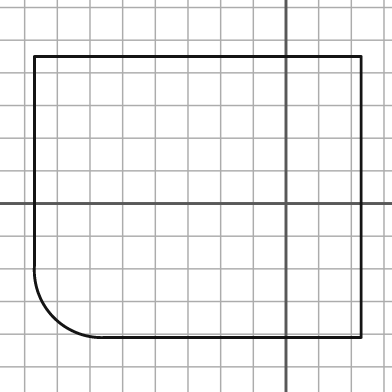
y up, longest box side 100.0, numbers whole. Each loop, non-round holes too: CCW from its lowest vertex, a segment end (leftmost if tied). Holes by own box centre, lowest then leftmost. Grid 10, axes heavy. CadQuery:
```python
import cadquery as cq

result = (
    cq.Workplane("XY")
    .moveTo(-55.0, -41.0)
    .lineTo(23.0, -41.0)
    .lineTo(23.0, 45.0)
    .lineTo(-77.0, 45.0)
    .lineTo(-77.0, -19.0)
    .threePointArc((-71.0, -35.0), (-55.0, -41.0))
    .close()
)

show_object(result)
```